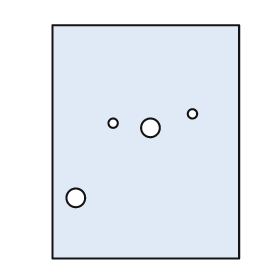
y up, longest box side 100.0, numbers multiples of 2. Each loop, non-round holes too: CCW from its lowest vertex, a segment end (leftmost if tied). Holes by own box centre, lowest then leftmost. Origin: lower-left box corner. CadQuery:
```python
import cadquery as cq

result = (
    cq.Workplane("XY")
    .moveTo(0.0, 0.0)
    .lineTo(80.0, 0.0)
    .lineTo(80.0, 100.0)
    .lineTo(0.0, 100.0)
    .close()
    .moveTo(10.0, 26.0)
    .circle(4.0)
    .moveTo(42.0, 56.0)
    .circle(4.0)
    .moveTo(26.0, 58.0)
    .circle(2.0)
    .moveTo(60.0, 62.0)
    .circle(2.0)
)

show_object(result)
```